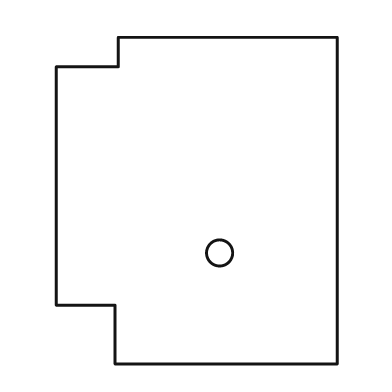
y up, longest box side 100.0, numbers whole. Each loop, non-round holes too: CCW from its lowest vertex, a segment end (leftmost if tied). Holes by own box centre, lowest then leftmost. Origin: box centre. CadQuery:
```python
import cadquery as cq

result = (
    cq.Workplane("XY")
    .moveTo(-25.0, -50.0)
    .lineTo(43.0, -50.0)
    .lineTo(43.0, 50.0)
    .lineTo(-24.0, 50.0)
    .lineTo(-24.0, 41.0)
    .lineTo(-43.0, 41.0)
    .lineTo(-43.0, -32.0)
    .lineTo(-25.0, -32.0)
    .close()
    .moveTo(7.0, -16.0)
    .circle(4.0)
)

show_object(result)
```